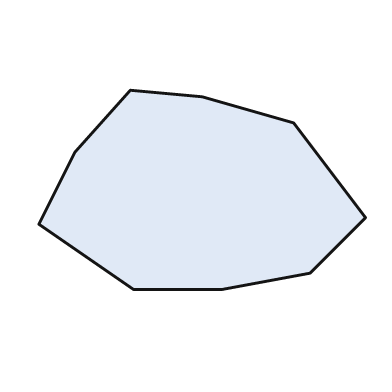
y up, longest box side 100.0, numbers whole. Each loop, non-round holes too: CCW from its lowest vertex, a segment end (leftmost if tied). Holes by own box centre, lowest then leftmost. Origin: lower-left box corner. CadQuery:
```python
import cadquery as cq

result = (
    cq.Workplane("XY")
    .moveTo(29.0, 0.0)
    .lineTo(56.0, 0.0)
    .lineTo(83.0, 5.0)
    .lineTo(100.0, 22.0)
    .lineTo(78.0, 51.0)
    .lineTo(50.0, 59.0)
    .lineTo(28.0, 61.0)
    .lineTo(11.0, 42.0)
    .lineTo(0.0, 20.0)
    .close()
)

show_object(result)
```